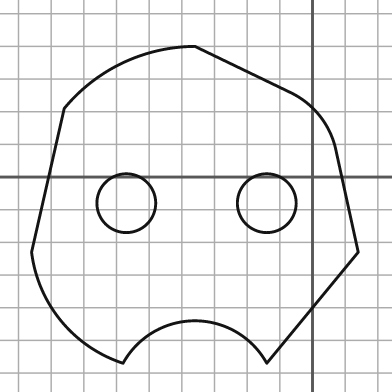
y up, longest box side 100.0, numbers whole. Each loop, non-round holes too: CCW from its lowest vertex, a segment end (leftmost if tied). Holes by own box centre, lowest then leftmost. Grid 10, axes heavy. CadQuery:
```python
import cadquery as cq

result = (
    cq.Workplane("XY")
    .moveTo(-58.0, -57.0)
    .threePointArc((-36.0, -44.0), (-14.0, -57.0))
    .lineTo(14.0, -23.0)
    .lineTo(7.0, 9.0)
    .threePointArc((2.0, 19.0), (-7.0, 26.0))
    .lineTo(-36.0, 40.0)
    .threePointArc((-58.0, 35.0), (-76.0, 21.0))
    .lineTo(-86.0, -23.0)
    .threePointArc((-77.0, -44.0), (-58.0, -57.0))
    .close()
    .moveTo(-57.0, -8.0)
    .circle(9.0)
    .moveTo(-14.0, -8.0)
    .circle(9.0)
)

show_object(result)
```